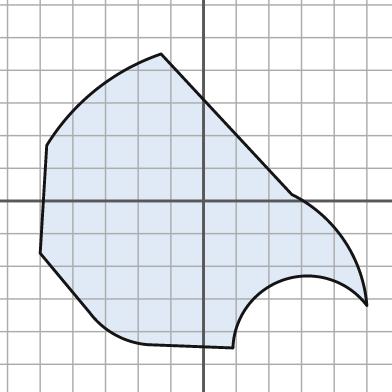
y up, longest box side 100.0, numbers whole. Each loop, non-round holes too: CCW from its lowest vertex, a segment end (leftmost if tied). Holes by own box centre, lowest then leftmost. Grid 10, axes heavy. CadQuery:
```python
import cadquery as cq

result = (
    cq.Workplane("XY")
    .moveTo(9.0, -45.0)
    .threePointArc((25.0, -24.0), (50.0, -32.0))
    .threePointArc((43.0, -12.0), (27.0, 2.0))
    .lineTo(-13.0, 45.0)
    .threePointArc((-33.0, 34.0), (-48.0, 17.0))
    .lineTo(-50.0, -16.0)
    .lineTo(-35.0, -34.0)
    .threePointArc((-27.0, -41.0), (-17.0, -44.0))
    .close()
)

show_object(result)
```